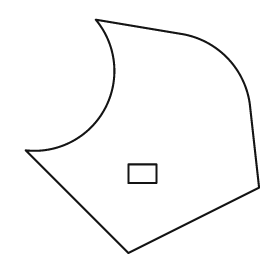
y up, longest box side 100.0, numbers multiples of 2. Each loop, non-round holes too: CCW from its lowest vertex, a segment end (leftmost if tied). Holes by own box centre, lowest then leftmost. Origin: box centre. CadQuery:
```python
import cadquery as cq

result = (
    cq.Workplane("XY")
    .moveTo(-6.0, -50.0)
    .lineTo(50.0, -22.0)
    .lineTo(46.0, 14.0)
    .threePointArc((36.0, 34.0), (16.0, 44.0))
    .lineTo(-20.0, 50.0)
    .threePointArc((-16.0, 12.0), (-50.0, -6.0))
    .close()
    .moveTo(-6.0, -20.0)
    .lineTo(6.0, -20.0)
    .lineTo(6.0, -12.0)
    .lineTo(-6.0, -12.0)
    .close()
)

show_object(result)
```